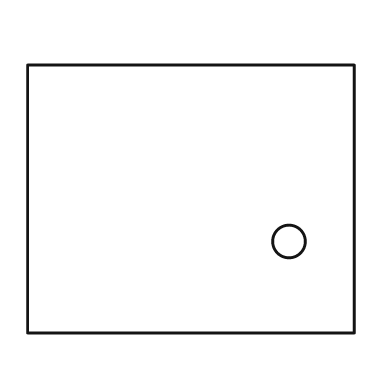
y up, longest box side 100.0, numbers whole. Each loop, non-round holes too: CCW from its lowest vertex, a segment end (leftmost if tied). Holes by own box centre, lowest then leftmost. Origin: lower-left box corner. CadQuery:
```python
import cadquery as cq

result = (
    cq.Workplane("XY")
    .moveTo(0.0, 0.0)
    .lineTo(100.0, 0.0)
    .lineTo(100.0, 82.0)
    .lineTo(0.0, 82.0)
    .close()
    .moveTo(80.0, 28.0)
    .circle(5.0)
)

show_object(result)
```